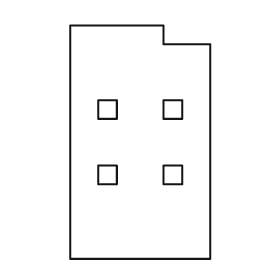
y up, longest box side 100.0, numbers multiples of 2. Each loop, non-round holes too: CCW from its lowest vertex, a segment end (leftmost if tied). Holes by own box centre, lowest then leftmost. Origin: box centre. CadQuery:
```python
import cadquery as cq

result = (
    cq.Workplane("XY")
    .moveTo(-30.0, -50.0)
    .lineTo(30.0, -50.0)
    .lineTo(30.0, 42.0)
    .lineTo(10.0, 42.0)
    .lineTo(10.0, 50.0)
    .lineTo(-30.0, 50.0)
    .close()
    .moveTo(-18.0, -18.0)
    .lineTo(-10.0, -18.0)
    .lineTo(-10.0, -10.0)
    .lineTo(-18.0, -10.0)
    .close()
    .moveTo(10.0, -18.0)
    .lineTo(18.0, -18.0)
    .lineTo(18.0, -10.0)
    .lineTo(10.0, -10.0)
    .close()
    .moveTo(-18.0, 10.0)
    .lineTo(-10.0, 10.0)
    .lineTo(-10.0, 18.0)
    .lineTo(-18.0, 18.0)
    .close()
    .moveTo(10.0, 10.0)
    .lineTo(18.0, 10.0)
    .lineTo(18.0, 18.0)
    .lineTo(10.0, 18.0)
    .close()
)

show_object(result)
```